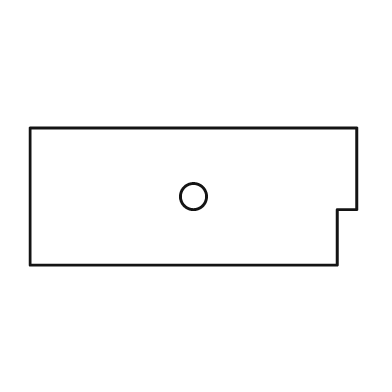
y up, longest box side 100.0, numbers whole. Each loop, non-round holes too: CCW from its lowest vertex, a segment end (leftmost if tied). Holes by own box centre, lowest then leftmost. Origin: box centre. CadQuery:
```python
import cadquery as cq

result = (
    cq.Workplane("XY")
    .moveTo(-50.0, -21.0)
    .lineTo(44.0, -21.0)
    .lineTo(44.0, -4.0)
    .lineTo(50.0, -4.0)
    .lineTo(50.0, 21.0)
    .lineTo(-50.0, 21.0)
    .close()
    .moveTo(0.0, 0.0)
    .circle(4.0)
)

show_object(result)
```